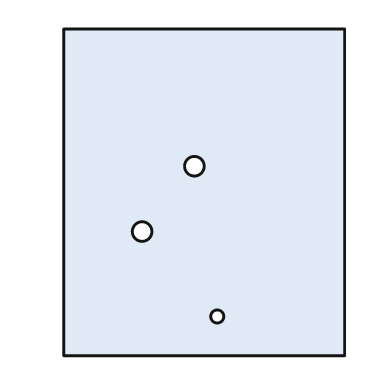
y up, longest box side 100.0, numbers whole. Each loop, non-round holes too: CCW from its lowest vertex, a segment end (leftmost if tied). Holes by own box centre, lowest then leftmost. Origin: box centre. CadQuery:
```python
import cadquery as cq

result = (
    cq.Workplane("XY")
    .moveTo(-43.0, -50.0)
    .lineTo(43.0, -50.0)
    .lineTo(43.0, 50.0)
    .lineTo(-43.0, 50.0)
    .close()
    .moveTo(4.0, -38.0)
    .circle(2.0)
    .moveTo(-19.0, -12.0)
    .circle(3.0)
    .moveTo(-3.0, 8.0)
    .circle(3.0)
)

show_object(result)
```